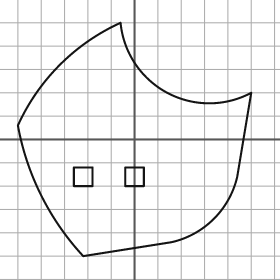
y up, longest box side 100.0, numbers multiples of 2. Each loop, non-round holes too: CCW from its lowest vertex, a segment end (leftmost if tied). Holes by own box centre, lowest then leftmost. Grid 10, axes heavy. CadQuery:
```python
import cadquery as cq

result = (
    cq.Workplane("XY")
    .moveTo(-22.0, -50.0)
    .lineTo(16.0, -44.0)
    .threePointArc((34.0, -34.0), (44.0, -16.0))
    .lineTo(50.0, 20.0)
    .threePointArc((14.0, 20.0), (-6.0, 50.0))
    .threePointArc((-32.0, 32.0), (-50.0, 6.0))
    .threePointArc((-40.0, -24.0), (-22.0, -50.0))
    .close()
    .moveTo(-26.0, -20.0)
    .lineTo(-18.0, -20.0)
    .lineTo(-18.0, -12.0)
    .lineTo(-26.0, -12.0)
    .close()
    .moveTo(-4.0, -20.0)
    .lineTo(4.0, -20.0)
    .lineTo(4.0, -12.0)
    .lineTo(-4.0, -12.0)
    .close()
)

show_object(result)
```